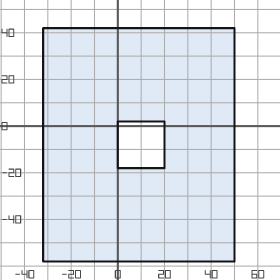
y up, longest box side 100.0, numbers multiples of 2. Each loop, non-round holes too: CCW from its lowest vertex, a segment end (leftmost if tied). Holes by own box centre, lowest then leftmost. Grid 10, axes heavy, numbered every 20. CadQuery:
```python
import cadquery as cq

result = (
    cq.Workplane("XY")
    .moveTo(-32.0, -58.0)
    .lineTo(50.0, -58.0)
    .lineTo(50.0, 42.0)
    .lineTo(-32.0, 42.0)
    .close()
    .moveTo(0.0, -18.0)
    .lineTo(20.0, -18.0)
    .lineTo(20.0, 2.0)
    .lineTo(0.0, 2.0)
    .close()
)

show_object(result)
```